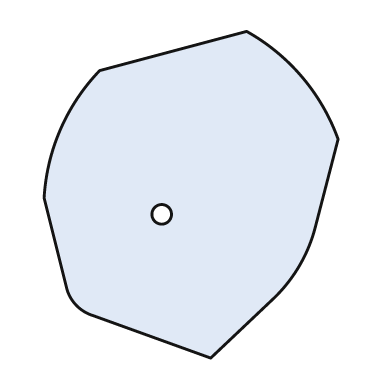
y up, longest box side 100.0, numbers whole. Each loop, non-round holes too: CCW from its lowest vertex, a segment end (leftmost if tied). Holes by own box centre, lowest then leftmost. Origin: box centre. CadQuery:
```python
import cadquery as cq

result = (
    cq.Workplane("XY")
    .moveTo(6.0, -50.0)
    .lineTo(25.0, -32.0)
    .threePointArc((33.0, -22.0), (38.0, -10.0))
    .lineTo(45.0, 17.0)
    .threePointArc((34.0, 36.0), (17.0, 50.0))
    .lineTo(-28.0, 38.0)
    .threePointArc((-40.0, 20.0), (-45.0, -1.0))
    .lineTo(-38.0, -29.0)
    .threePointArc((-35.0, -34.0), (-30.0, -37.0))
    .close()
    .moveTo(-9.0, -6.0)
    .circle(3.0)
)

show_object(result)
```